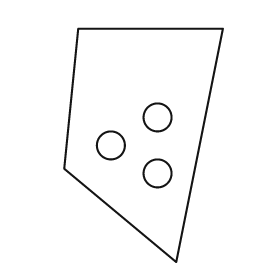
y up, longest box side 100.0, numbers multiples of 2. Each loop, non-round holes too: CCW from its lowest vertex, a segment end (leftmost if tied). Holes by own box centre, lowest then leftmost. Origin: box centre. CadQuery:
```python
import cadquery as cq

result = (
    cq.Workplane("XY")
    .moveTo(14.0, -50.0)
    .lineTo(34.0, 50.0)
    .lineTo(-28.0, 50.0)
    .lineTo(-34.0, -10.0)
    .close()
    .moveTo(6.0, -12.0)
    .circle(6.0)
    .moveTo(-14.0, 0.0)
    .circle(6.0)
    .moveTo(6.0, 12.0)
    .circle(6.0)
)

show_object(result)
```